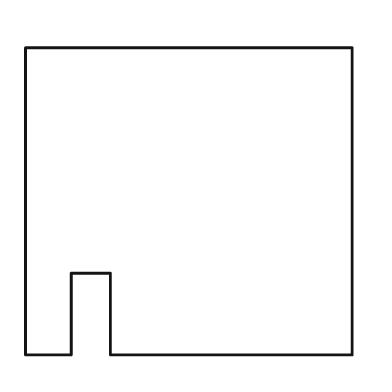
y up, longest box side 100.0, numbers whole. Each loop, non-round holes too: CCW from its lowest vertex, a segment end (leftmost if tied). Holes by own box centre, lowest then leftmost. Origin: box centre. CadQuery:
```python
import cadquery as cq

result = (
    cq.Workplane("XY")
    .moveTo(-50.0, -47.0)
    .lineTo(-36.0, -47.0)
    .lineTo(-36.0, -22.0)
    .lineTo(-24.0, -22.0)
    .lineTo(-24.0, -47.0)
    .lineTo(50.0, -47.0)
    .lineTo(50.0, 47.0)
    .lineTo(-50.0, 47.0)
    .close()
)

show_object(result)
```